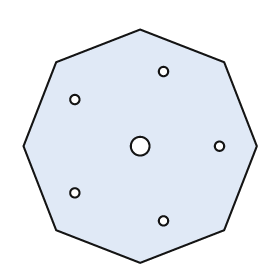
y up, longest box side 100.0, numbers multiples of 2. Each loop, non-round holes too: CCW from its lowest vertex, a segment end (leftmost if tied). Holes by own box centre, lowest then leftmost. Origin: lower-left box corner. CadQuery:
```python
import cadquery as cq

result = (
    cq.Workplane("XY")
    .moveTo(50.0, 0.0)
    .lineTo(86.0, 14.0)
    .lineTo(100.0, 50.0)
    .lineTo(86.0, 86.0)
    .lineTo(50.0, 100.0)
    .lineTo(14.0, 86.0)
    .lineTo(0.0, 50.0)
    .lineTo(14.0, 14.0)
    .close()
    .moveTo(60.0, 18.0)
    .circle(2.0)
    .moveTo(22.0, 30.0)
    .circle(2.0)
    .moveTo(50.0, 50.0)
    .circle(4.0)
    .moveTo(84.0, 50.0)
    .circle(2.0)
    .moveTo(22.0, 70.0)
    .circle(2.0)
    .moveTo(60.0, 82.0)
    .circle(2.0)
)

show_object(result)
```